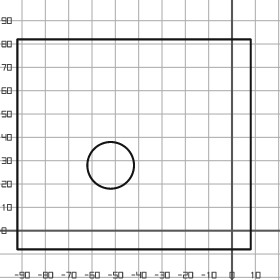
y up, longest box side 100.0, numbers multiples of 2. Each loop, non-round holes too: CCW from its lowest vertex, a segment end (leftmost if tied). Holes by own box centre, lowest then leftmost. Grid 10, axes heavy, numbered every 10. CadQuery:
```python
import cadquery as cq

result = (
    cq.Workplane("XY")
    .moveTo(-92.0, -8.0)
    .lineTo(8.0, -8.0)
    .lineTo(8.0, 82.0)
    .lineTo(-92.0, 82.0)
    .close()
    .moveTo(-52.0, 28.0)
    .circle(10.0)
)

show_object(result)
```